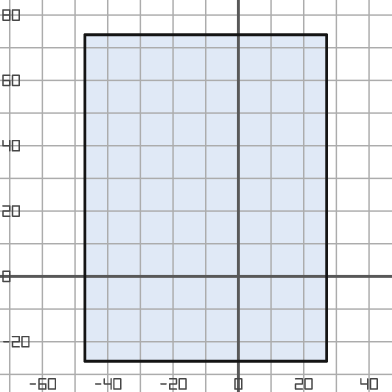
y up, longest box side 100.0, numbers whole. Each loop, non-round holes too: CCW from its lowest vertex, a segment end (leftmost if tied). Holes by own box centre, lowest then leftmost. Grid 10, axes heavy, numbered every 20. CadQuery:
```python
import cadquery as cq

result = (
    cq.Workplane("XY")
    .moveTo(-47.0, -26.0)
    .lineTo(27.0, -26.0)
    .lineTo(27.0, 74.0)
    .lineTo(-47.0, 74.0)
    .close()
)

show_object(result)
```